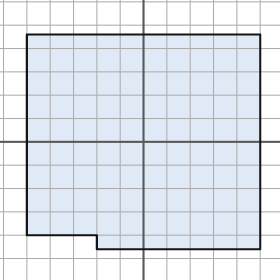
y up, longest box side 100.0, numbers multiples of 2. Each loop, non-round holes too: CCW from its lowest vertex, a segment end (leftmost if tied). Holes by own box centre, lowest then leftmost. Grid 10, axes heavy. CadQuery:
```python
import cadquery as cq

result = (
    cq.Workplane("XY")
    .moveTo(-20.0, -46.0)
    .lineTo(50.0, -46.0)
    .lineTo(50.0, 46.0)
    .lineTo(-50.0, 46.0)
    .lineTo(-50.0, -40.0)
    .lineTo(-20.0, -40.0)
    .close()
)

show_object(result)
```